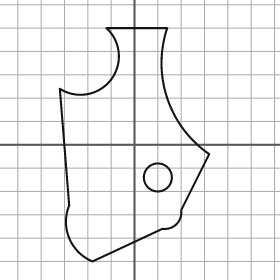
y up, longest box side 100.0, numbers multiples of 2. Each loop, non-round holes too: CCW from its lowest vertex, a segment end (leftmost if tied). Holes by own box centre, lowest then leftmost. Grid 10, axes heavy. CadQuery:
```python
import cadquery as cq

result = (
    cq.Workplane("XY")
    .moveTo(-18.0, -50.0)
    .lineTo(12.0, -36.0)
    .threePointArc((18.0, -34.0), (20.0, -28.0))
    .lineTo(32.0, -4.0)
    .threePointArc((14.0, 20.0), (14.0, 50.0))
    .lineTo(-12.0, 50.0)
    .threePointArc((-10.0, 28.0), (-32.0, 24.0))
    .lineTo(-28.0, -26.0)
    .threePointArc((-28.0, -40.0), (-18.0, -50.0))
    .close()
    .moveTo(10.0, -14.0)
    .circle(6.0)
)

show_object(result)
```